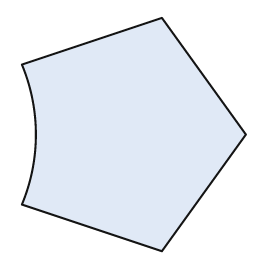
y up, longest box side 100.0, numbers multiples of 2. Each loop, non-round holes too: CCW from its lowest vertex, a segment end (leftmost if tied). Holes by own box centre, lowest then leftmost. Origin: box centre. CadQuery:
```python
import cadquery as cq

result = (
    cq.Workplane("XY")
    .moveTo(12.0, -50.0)
    .lineTo(48.0, 0.0)
    .lineTo(12.0, 50.0)
    .lineTo(-48.0, 30.0)
    .threePointArc((-42.0, 0.0), (-48.0, -30.0))
    .close()
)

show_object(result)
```